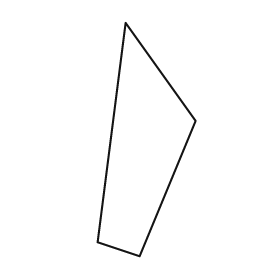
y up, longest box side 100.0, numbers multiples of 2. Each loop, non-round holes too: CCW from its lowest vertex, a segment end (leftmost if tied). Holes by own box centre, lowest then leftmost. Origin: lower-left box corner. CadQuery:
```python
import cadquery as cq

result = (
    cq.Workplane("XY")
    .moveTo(18.0, 0.0)
    .lineTo(42.0, 58.0)
    .lineTo(12.0, 100.0)
    .lineTo(0.0, 6.0)
    .close()
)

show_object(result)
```